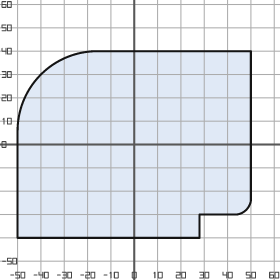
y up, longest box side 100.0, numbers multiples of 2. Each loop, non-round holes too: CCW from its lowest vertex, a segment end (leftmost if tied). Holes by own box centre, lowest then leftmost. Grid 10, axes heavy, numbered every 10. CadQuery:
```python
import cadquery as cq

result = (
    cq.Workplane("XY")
    .moveTo(-50.0, -40.0)
    .lineTo(28.0, -40.0)
    .lineTo(28.0, -30.0)
    .lineTo(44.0, -30.0)
    .threePointArc((48.0, -28.0), (50.0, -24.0))
    .lineTo(50.0, 40.0)
    .lineTo(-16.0, 40.0)
    .threePointArc((-40.0, 30.0), (-50.0, 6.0))
    .close()
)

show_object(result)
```